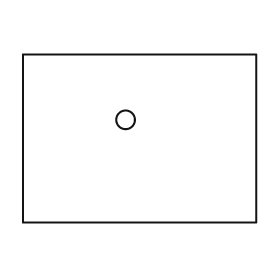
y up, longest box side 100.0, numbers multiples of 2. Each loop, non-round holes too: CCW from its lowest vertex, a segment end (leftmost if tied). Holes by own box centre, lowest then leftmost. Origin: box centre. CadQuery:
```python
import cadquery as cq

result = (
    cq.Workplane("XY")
    .moveTo(-50.0, -36.0)
    .lineTo(50.0, -36.0)
    .lineTo(50.0, 36.0)
    .lineTo(-50.0, 36.0)
    .close()
    .moveTo(-6.0, 8.0)
    .circle(4.0)
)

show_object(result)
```